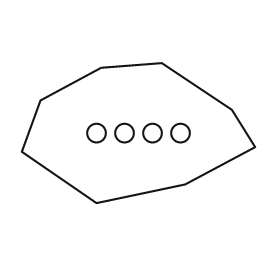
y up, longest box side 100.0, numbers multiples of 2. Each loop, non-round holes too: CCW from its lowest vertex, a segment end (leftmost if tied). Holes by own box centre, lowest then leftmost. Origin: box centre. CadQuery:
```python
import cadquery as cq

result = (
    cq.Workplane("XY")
    .moveTo(-18.0, -30.0)
    .lineTo(20.0, -22.0)
    .lineTo(50.0, -6.0)
    .lineTo(40.0, 10.0)
    .lineTo(10.0, 30.0)
    .lineTo(-16.0, 28.0)
    .lineTo(-42.0, 14.0)
    .lineTo(-50.0, -8.0)
    .close()
    .moveTo(-18.0, 0.0)
    .circle(4.0)
    .moveTo(-6.0, 0.0)
    .circle(4.0)
    .moveTo(6.0, 0.0)
    .circle(4.0)
    .moveTo(18.0, 0.0)
    .circle(4.0)
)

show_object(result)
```